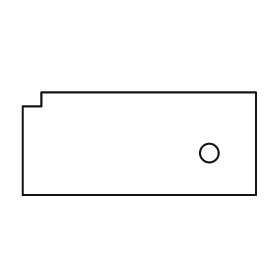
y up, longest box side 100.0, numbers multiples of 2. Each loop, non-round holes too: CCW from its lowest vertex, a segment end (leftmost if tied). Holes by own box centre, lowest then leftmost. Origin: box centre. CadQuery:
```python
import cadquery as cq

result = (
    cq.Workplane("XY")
    .moveTo(-50.0, -22.0)
    .lineTo(50.0, -22.0)
    .lineTo(50.0, 22.0)
    .lineTo(-42.0, 22.0)
    .lineTo(-42.0, 16.0)
    .lineTo(-50.0, 16.0)
    .close()
    .moveTo(30.0, -4.0)
    .circle(4.0)
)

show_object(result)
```